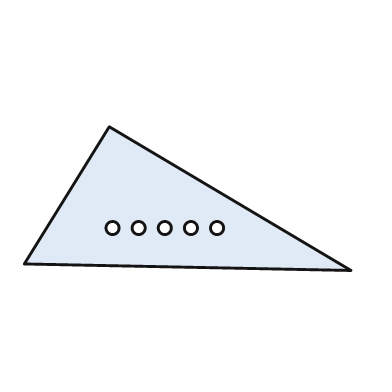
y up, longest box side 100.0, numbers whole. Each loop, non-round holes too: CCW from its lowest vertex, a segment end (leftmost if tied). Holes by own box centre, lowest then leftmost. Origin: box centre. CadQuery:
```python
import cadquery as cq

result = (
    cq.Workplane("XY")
    .moveTo(50.0, -22.0)
    .lineTo(-24.0, 22.0)
    .lineTo(-50.0, -20.0)
    .close()
    .moveTo(-23.0, -9.0)
    .circle(2.0)
    .moveTo(-15.0, -9.0)
    .circle(2.0)
    .moveTo(-7.0, -9.0)
    .circle(2.0)
    .moveTo(1.0, -9.0)
    .circle(2.0)
    .moveTo(9.0, -9.0)
    .circle(2.0)
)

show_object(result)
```